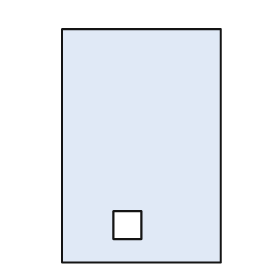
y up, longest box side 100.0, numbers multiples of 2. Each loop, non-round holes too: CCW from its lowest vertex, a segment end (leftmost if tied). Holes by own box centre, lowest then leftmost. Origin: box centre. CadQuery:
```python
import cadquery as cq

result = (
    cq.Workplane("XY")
    .moveTo(-34.0, -50.0)
    .lineTo(34.0, -50.0)
    .lineTo(34.0, 50.0)
    .lineTo(-34.0, 50.0)
    .close()
    .moveTo(-12.0, -40.0)
    .lineTo(0.0, -40.0)
    .lineTo(0.0, -28.0)
    .lineTo(-12.0, -28.0)
    .close()
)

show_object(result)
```